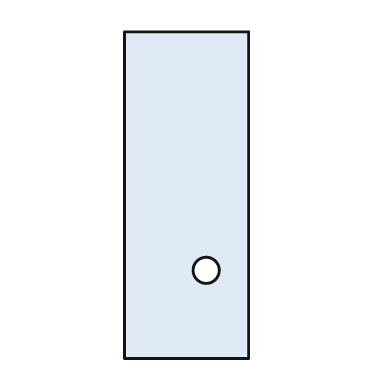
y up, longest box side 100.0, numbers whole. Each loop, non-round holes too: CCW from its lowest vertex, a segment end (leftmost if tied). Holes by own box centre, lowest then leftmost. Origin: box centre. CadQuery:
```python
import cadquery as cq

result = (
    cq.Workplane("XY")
    .moveTo(-19.0, -50.0)
    .lineTo(19.0, -50.0)
    .lineTo(19.0, 50.0)
    .lineTo(-19.0, 50.0)
    .close()
    .moveTo(6.0, -23.0)
    .circle(4.0)
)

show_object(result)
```